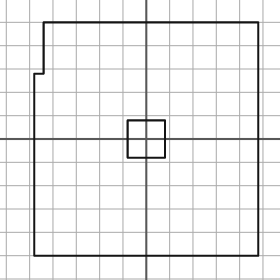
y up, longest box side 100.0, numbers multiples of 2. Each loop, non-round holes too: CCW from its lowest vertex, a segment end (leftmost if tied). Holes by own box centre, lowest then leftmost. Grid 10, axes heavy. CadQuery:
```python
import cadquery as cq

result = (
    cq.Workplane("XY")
    .moveTo(-48.0, -50.0)
    .lineTo(48.0, -50.0)
    .lineTo(48.0, 50.0)
    .lineTo(-44.0, 50.0)
    .lineTo(-44.0, 28.0)
    .lineTo(-48.0, 28.0)
    .close()
    .moveTo(-8.0, -8.0)
    .lineTo(8.0, -8.0)
    .lineTo(8.0, 8.0)
    .lineTo(-8.0, 8.0)
    .close()
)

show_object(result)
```